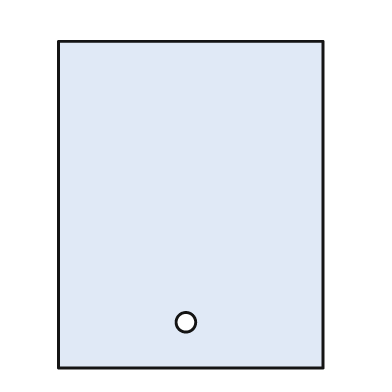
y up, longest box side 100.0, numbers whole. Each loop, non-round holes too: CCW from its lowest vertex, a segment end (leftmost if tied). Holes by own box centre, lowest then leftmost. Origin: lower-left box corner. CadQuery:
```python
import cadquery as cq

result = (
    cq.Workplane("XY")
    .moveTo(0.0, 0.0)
    .lineTo(81.0, 0.0)
    .lineTo(81.0, 100.0)
    .lineTo(0.0, 100.0)
    .close()
    .moveTo(39.0, 14.0)
    .circle(3.0)
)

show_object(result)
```